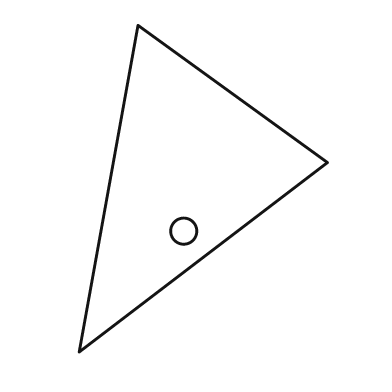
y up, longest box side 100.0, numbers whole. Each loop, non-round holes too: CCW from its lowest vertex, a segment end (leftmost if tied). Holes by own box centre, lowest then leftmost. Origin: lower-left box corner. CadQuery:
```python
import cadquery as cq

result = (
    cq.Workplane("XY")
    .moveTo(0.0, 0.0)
    .lineTo(76.0, 58.0)
    .lineTo(18.0, 100.0)
    .close()
    .moveTo(32.0, 37.0)
    .circle(4.0)
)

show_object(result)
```